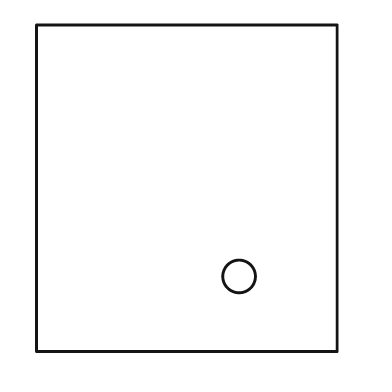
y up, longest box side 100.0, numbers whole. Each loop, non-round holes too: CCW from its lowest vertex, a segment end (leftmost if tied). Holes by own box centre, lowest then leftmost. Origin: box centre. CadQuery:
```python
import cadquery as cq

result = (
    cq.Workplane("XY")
    .moveTo(-46.0, -50.0)
    .lineTo(46.0, -50.0)
    .lineTo(46.0, 50.0)
    .lineTo(-46.0, 50.0)
    .close()
    .moveTo(16.0, -27.0)
    .circle(5.0)
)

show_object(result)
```